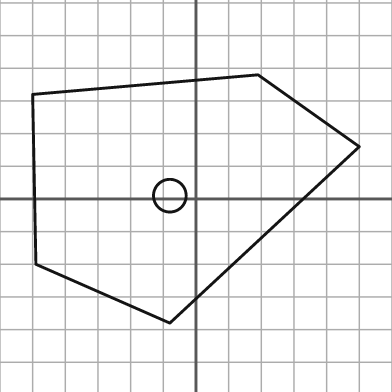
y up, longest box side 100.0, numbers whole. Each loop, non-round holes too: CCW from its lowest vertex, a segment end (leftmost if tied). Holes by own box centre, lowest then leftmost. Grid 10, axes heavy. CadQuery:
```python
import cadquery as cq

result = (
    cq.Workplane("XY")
    .moveTo(-8.0, -38.0)
    .lineTo(50.0, 16.0)
    .lineTo(19.0, 38.0)
    .lineTo(-50.0, 32.0)
    .lineTo(-49.0, -20.0)
    .close()
    .moveTo(-8.0, 1.0)
    .circle(5.0)
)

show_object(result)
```